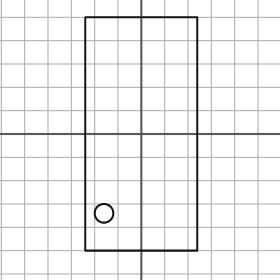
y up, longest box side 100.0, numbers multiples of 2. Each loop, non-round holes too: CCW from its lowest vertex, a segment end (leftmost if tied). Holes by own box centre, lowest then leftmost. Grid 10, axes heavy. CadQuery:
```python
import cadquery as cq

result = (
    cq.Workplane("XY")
    .moveTo(-24.0, -50.0)
    .lineTo(24.0, -50.0)
    .lineTo(24.0, 50.0)
    .lineTo(-24.0, 50.0)
    .close()
    .moveTo(-16.0, -34.0)
    .circle(4.0)
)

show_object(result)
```